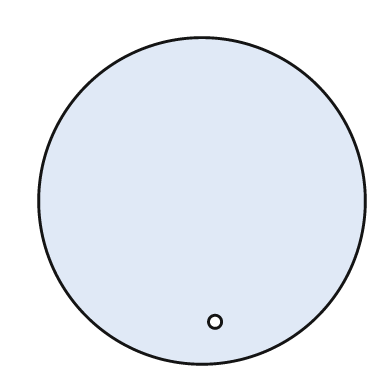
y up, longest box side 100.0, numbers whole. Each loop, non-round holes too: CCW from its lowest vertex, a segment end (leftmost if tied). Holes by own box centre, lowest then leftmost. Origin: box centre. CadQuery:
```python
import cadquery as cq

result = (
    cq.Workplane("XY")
    .moveTo(0.0, 0.0)
    .circle(50.0)
    .moveTo(4.0, -37.0)
    .circle(2.0)
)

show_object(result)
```